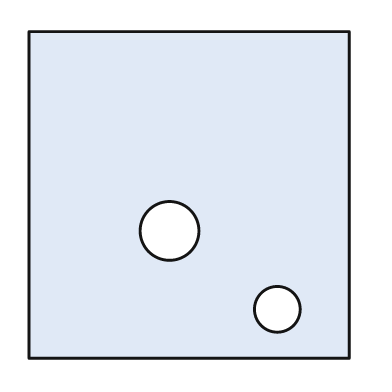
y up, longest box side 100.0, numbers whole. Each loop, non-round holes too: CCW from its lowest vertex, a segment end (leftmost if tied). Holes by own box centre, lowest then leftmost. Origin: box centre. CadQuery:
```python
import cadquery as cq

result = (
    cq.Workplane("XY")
    .moveTo(-49.0, -50.0)
    .lineTo(49.0, -50.0)
    .lineTo(49.0, 50.0)
    .lineTo(-49.0, 50.0)
    .close()
    .moveTo(27.0, -35.0)
    .circle(7.0)
    .moveTo(-6.0, -11.0)
    .circle(9.0)
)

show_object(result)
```